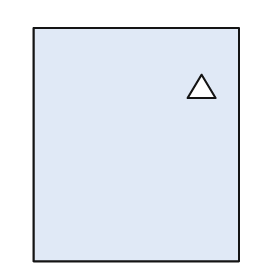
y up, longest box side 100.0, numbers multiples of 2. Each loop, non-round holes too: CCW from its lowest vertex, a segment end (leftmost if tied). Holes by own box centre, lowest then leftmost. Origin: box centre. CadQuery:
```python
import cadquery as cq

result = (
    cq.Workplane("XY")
    .moveTo(-44.0, -50.0)
    .lineTo(44.0, -50.0)
    .lineTo(44.0, 50.0)
    .lineTo(-44.0, 50.0)
    .close()
    .moveTo(22.0, 20.0)
    .lineTo(34.0, 20.0)
    .lineTo(28.0, 30.0)
    .close()
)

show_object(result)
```